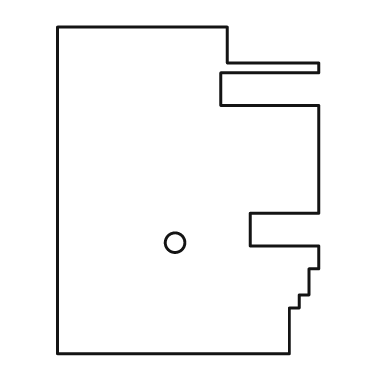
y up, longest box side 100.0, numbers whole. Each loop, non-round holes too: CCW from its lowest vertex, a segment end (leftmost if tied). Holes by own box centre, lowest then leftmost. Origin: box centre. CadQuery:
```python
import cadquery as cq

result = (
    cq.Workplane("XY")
    .moveTo(-40.0, -50.0)
    .lineTo(31.0, -50.0)
    .lineTo(31.0, -36.0)
    .lineTo(34.0, -36.0)
    .lineTo(34.0, -32.0)
    .lineTo(37.0, -32.0)
    .lineTo(37.0, -24.0)
    .lineTo(40.0, -24.0)
    .lineTo(40.0, -17.0)
    .lineTo(19.0, -17.0)
    .lineTo(19.0, -7.0)
    .lineTo(40.0, -7.0)
    .lineTo(40.0, 26.0)
    .lineTo(10.0, 26.0)
    .lineTo(10.0, 36.0)
    .lineTo(40.0, 36.0)
    .lineTo(40.0, 39.0)
    .lineTo(12.0, 39.0)
    .lineTo(12.0, 50.0)
    .lineTo(-40.0, 50.0)
    .close()
    .moveTo(-4.0, -16.0)
    .circle(3.0)
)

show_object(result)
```